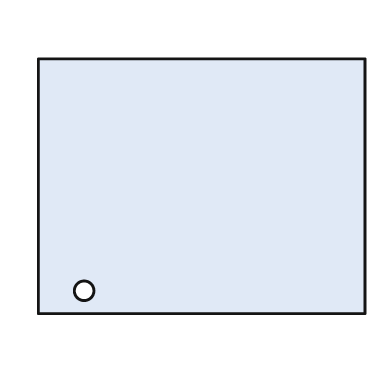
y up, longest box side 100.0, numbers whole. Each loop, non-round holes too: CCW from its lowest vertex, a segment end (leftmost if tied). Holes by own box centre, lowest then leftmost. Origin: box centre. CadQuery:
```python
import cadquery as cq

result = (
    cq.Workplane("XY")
    .moveTo(-50.0, -39.0)
    .lineTo(50.0, -39.0)
    .lineTo(50.0, 39.0)
    .lineTo(-50.0, 39.0)
    .close()
    .moveTo(-36.0, -32.0)
    .circle(3.0)
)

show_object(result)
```